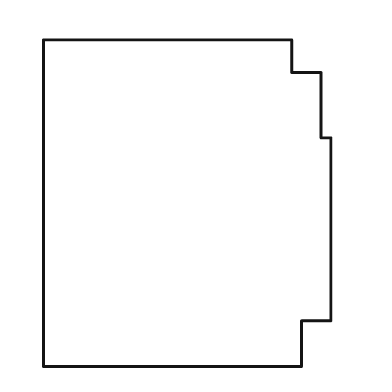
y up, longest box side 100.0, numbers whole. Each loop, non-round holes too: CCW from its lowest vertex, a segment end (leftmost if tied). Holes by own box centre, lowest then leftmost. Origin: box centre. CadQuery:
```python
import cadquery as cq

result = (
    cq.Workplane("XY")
    .moveTo(-44.0, -50.0)
    .lineTo(35.0, -50.0)
    .lineTo(35.0, -36.0)
    .lineTo(44.0, -36.0)
    .lineTo(44.0, 20.0)
    .lineTo(41.0, 20.0)
    .lineTo(41.0, 40.0)
    .lineTo(32.0, 40.0)
    .lineTo(32.0, 50.0)
    .lineTo(-44.0, 50.0)
    .close()
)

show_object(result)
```